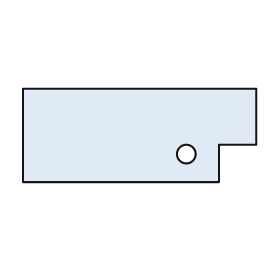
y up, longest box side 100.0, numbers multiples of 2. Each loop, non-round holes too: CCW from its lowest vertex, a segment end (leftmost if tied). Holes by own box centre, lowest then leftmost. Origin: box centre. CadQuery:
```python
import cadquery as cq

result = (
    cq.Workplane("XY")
    .moveTo(-50.0, -20.0)
    .lineTo(34.0, -20.0)
    .lineTo(34.0, -4.0)
    .lineTo(50.0, -4.0)
    .lineTo(50.0, 20.0)
    .lineTo(-50.0, 20.0)
    .close()
    .moveTo(20.0, -8.0)
    .circle(4.0)
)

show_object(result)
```